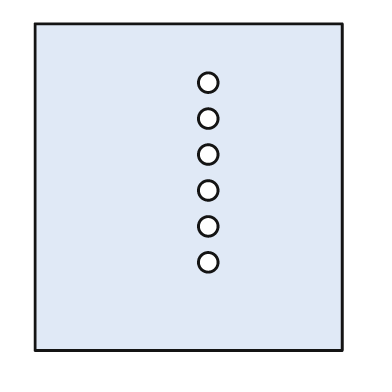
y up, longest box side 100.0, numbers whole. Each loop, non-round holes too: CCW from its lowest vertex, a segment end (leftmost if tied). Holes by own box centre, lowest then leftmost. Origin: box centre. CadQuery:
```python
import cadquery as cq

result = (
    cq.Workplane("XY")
    .moveTo(-47.0, -50.0)
    .lineTo(47.0, -50.0)
    .lineTo(47.0, 50.0)
    .lineTo(-47.0, 50.0)
    .close()
    .moveTo(6.0, -23.0)
    .circle(3.0)
    .moveTo(6.0, -12.0)
    .circle(3.0)
    .moveTo(6.0, -1.0)
    .circle(3.0)
    .moveTo(6.0, 10.0)
    .circle(3.0)
    .moveTo(6.0, 21.0)
    .circle(3.0)
    .moveTo(6.0, 32.0)
    .circle(3.0)
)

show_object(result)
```